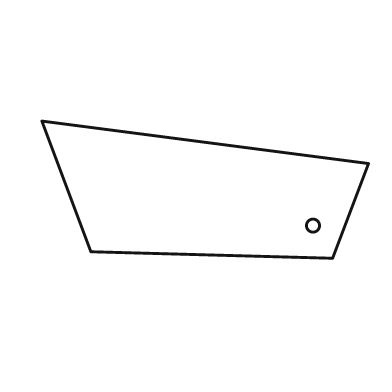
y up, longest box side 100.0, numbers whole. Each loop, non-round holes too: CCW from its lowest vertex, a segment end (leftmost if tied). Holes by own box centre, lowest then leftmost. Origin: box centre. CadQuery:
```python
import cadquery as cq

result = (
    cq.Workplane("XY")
    .moveTo(39.0, -21.0)
    .lineTo(50.0, 8.0)
    .lineTo(-50.0, 21.0)
    .lineTo(-35.0, -19.0)
    .close()
    .moveTo(33.0, -11.0)
    .circle(2.0)
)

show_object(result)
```